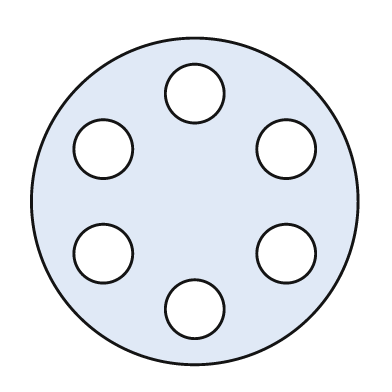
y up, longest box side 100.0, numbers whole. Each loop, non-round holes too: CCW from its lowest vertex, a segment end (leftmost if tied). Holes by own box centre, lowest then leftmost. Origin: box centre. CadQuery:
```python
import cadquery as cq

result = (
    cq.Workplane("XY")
    .moveTo(0.0, 0.0)
    .circle(50.0)
    .moveTo(0.0, -33.0)
    .circle(9.0)
    .moveTo(-28.0, -16.0)
    .circle(9.0)
    .moveTo(28.0, -16.0)
    .circle(9.0)
    .moveTo(-28.0, 16.0)
    .circle(9.0)
    .moveTo(28.0, 16.0)
    .circle(9.0)
    .moveTo(0.0, 33.0)
    .circle(9.0)
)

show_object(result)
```